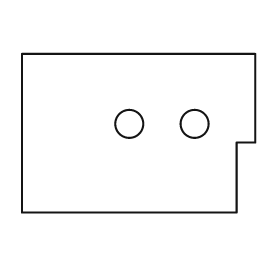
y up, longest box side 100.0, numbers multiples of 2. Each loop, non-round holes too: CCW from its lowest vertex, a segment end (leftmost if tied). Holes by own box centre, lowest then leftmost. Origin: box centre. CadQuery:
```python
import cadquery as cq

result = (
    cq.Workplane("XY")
    .moveTo(-50.0, -34.0)
    .lineTo(42.0, -34.0)
    .lineTo(42.0, -4.0)
    .lineTo(50.0, -4.0)
    .lineTo(50.0, 34.0)
    .lineTo(-50.0, 34.0)
    .close()
    .moveTo(-4.0, 4.0)
    .circle(6.0)
    .moveTo(24.0, 4.0)
    .circle(6.0)
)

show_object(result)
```